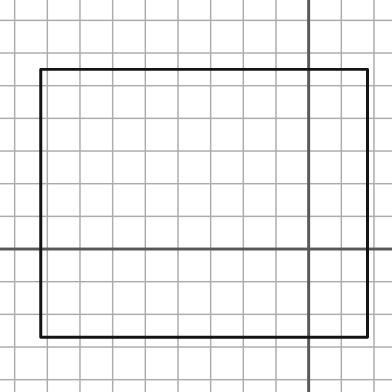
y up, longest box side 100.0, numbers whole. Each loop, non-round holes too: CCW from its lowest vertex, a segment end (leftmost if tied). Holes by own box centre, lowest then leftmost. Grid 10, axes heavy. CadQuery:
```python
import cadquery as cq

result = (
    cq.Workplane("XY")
    .moveTo(-82.0, -27.0)
    .lineTo(18.0, -27.0)
    .lineTo(18.0, 55.0)
    .lineTo(-82.0, 55.0)
    .close()
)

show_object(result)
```